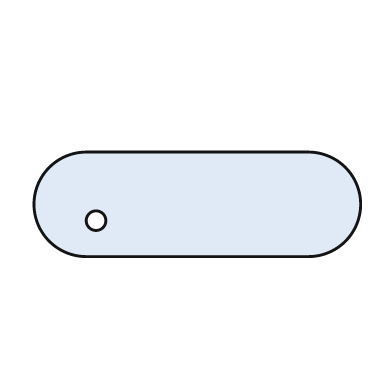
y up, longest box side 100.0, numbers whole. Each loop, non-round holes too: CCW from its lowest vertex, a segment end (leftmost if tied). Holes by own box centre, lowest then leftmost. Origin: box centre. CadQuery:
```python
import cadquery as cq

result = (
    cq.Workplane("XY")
    .moveTo(-34.0, -16.0)
    .lineTo(34.0, -16.0)
    .threePointArc((50.0, 0.0), (34.0, 16.0))
    .lineTo(-34.0, 16.0)
    .threePointArc((-50.0, 0.0), (-34.0, -16.0))
    .close()
    .moveTo(-31.0, -5.0)
    .circle(3.0)
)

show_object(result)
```